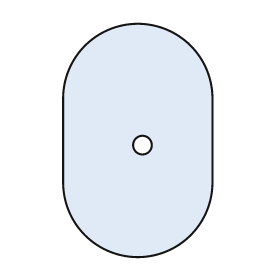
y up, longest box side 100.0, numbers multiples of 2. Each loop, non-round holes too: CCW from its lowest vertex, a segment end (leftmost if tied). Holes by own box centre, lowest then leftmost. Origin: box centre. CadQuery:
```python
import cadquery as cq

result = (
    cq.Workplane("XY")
    .moveTo(-32.0, -18.0)
    .threePointArc((0.0, -50.0), (32.0, -18.0))
    .lineTo(32.0, 18.0)
    .threePointArc((0.0, 50.0), (-32.0, 18.0))
    .close()
    .moveTo(2.0, -2.0)
    .circle(4.0)
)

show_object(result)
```